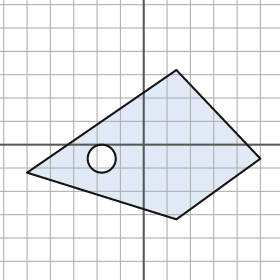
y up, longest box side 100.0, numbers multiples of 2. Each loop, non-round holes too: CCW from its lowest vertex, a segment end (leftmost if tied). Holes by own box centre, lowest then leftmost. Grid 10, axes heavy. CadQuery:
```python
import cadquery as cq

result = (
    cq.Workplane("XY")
    .moveTo(14.0, -32.0)
    .lineTo(50.0, -6.0)
    .lineTo(14.0, 32.0)
    .lineTo(-50.0, -12.0)
    .close()
    .moveTo(-18.0, -6.0)
    .circle(6.0)
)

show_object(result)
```